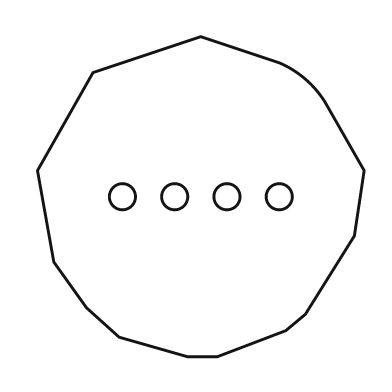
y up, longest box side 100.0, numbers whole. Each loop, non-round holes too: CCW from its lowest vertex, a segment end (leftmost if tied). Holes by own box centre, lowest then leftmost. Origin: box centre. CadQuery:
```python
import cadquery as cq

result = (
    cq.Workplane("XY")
    .moveTo(-4.0, -49.0)
    .lineTo(5.0, -49.0)
    .lineTo(26.0, -41.0)
    .lineTo(32.0, -36.0)
    .lineTo(47.0, -12.0)
    .lineTo(50.0, 8.0)
    .lineTo(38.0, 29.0)
    .threePointArc((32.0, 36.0), (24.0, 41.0))
    .lineTo(0.0, 49.0)
    .lineTo(-33.0, 38.0)
    .lineTo(-50.0, 8.0)
    .lineTo(-45.0, -20.0)
    .lineTo(-35.0, -34.0)
    .lineTo(-25.0, -43.0)
    .close()
    .moveTo(-24.0, 0.0)
    .circle(4.0)
    .moveTo(-8.0, 0.0)
    .circle(4.0)
    .moveTo(8.0, 0.0)
    .circle(4.0)
    .moveTo(24.0, 0.0)
    .circle(4.0)
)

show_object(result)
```